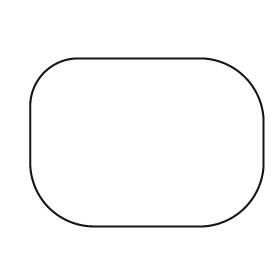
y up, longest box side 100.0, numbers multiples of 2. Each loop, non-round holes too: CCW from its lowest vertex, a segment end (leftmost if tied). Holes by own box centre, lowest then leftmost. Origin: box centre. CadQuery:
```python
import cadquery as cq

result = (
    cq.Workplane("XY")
    .moveTo(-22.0, -36.0)
    .lineTo(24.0, -36.0)
    .threePointArc((42.0, -28.0), (50.0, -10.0))
    .lineTo(50.0, 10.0)
    .threePointArc((42.0, 28.0), (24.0, 36.0))
    .lineTo(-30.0, 36.0)
    .threePointArc((-44.0, 30.0), (-50.0, 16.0))
    .lineTo(-50.0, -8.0)
    .threePointArc((-42.0, -28.0), (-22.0, -36.0))
    .close()
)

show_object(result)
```